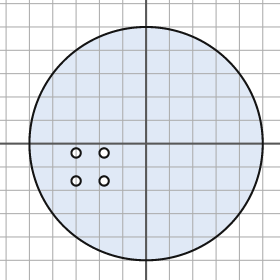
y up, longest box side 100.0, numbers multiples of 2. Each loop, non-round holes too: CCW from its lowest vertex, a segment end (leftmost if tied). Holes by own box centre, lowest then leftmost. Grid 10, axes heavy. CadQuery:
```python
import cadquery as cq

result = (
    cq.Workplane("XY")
    .moveTo(0.0, 0.0)
    .circle(50.0)
    .moveTo(-30.0, -16.0)
    .circle(2.0)
    .moveTo(-18.0, -16.0)
    .circle(2.0)
    .moveTo(-30.0, -4.0)
    .circle(2.0)
    .moveTo(-18.0, -4.0)
    .circle(2.0)
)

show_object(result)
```